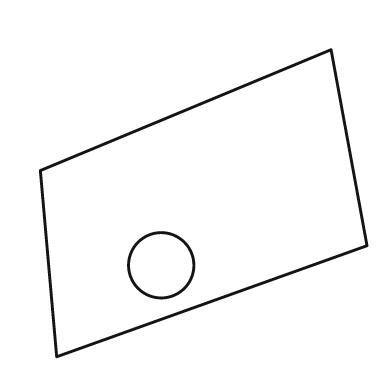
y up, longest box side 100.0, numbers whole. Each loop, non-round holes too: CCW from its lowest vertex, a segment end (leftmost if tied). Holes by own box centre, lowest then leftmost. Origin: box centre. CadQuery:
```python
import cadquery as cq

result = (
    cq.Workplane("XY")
    .moveTo(-45.0, -47.0)
    .lineTo(50.0, -13.0)
    .lineTo(39.0, 47.0)
    .lineTo(-50.0, 10.0)
    .close()
    .moveTo(-13.0, -19.0)
    .circle(10.0)
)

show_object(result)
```